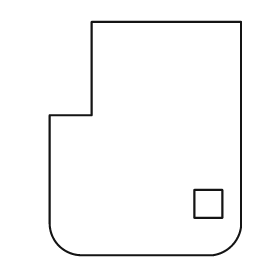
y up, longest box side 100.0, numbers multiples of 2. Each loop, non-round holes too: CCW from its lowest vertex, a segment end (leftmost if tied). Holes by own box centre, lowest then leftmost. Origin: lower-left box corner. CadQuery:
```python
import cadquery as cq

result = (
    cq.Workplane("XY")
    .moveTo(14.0, 0.0)
    .lineTo(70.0, 0.0)
    .threePointArc((78.0, 4.0), (82.0, 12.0))
    .lineTo(82.0, 100.0)
    .lineTo(18.0, 100.0)
    .lineTo(18.0, 60.0)
    .lineTo(0.0, 60.0)
    .lineTo(0.0, 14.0)
    .threePointArc((4.0, 4.0), (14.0, 0.0))
    .close()
    .moveTo(62.0, 16.0)
    .lineTo(74.0, 16.0)
    .lineTo(74.0, 28.0)
    .lineTo(62.0, 28.0)
    .close()
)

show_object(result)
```